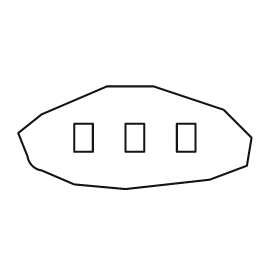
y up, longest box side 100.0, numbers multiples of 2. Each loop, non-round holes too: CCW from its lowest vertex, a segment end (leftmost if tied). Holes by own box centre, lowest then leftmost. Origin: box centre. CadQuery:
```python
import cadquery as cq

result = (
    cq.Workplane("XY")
    .moveTo(-4.0, -22.0)
    .lineTo(32.0, -18.0)
    .lineTo(48.0, -12.0)
    .lineTo(50.0, 0.0)
    .lineTo(38.0, 12.0)
    .lineTo(8.0, 22.0)
    .lineTo(-12.0, 22.0)
    .lineTo(-40.0, 10.0)
    .lineTo(-50.0, 2.0)
    .lineTo(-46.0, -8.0)
    .threePointArc((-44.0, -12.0), (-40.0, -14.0))
    .lineTo(-26.0, -20.0)
    .close()
    .moveTo(-26.0, -6.0)
    .lineTo(-18.0, -6.0)
    .lineTo(-18.0, 6.0)
    .lineTo(-26.0, 6.0)
    .close()
    .moveTo(-4.0, -6.0)
    .lineTo(4.0, -6.0)
    .lineTo(4.0, 6.0)
    .lineTo(-4.0, 6.0)
    .close()
    .moveTo(18.0, -6.0)
    .lineTo(26.0, -6.0)
    .lineTo(26.0, 6.0)
    .lineTo(18.0, 6.0)
    .close()
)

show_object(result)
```